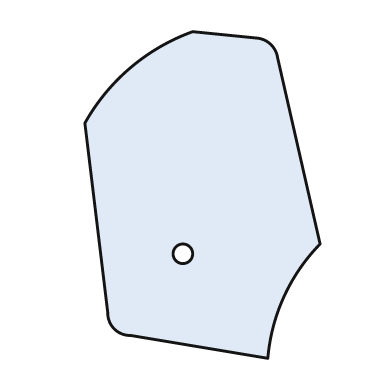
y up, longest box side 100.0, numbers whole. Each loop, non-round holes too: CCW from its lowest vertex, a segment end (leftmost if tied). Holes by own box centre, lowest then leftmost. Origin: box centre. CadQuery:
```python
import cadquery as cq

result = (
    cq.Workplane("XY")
    .moveTo(20.0, -50.0)
    .threePointArc((25.0, -31.0), (36.0, -15.0))
    .lineTo(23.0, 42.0)
    .threePointArc((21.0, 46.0), (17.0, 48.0))
    .lineTo(-3.0, 50.0)
    .threePointArc((-22.0, 39.0), (-36.0, 22.0))
    .lineTo(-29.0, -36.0)
    .threePointArc((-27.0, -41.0), (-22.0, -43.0))
    .close()
    .moveTo(-6.0, -18.0)
    .circle(3.0)
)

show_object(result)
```